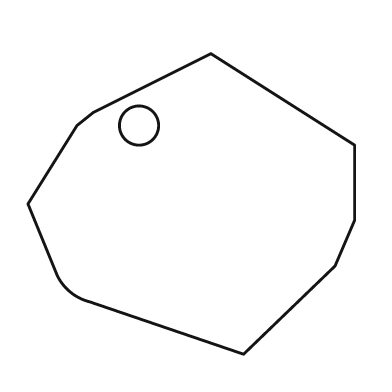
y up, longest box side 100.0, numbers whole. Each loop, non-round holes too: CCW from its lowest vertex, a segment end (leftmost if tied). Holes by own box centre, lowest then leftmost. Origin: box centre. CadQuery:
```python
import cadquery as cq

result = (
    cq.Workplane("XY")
    .moveTo(16.0, -46.0)
    .lineTo(44.0, -19.0)
    .lineTo(50.0, -5.0)
    .lineTo(50.0, 18.0)
    .lineTo(6.0, 46.0)
    .lineTo(-30.0, 28.0)
    .lineTo(-35.0, 24.0)
    .lineTo(-50.0, 0.0)
    .lineTo(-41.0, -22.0)
    .threePointArc((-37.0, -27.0), (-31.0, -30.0))
    .close()
    .moveTo(-16.0, 24.0)
    .circle(6.0)
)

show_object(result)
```